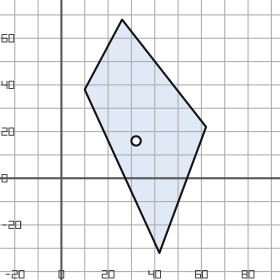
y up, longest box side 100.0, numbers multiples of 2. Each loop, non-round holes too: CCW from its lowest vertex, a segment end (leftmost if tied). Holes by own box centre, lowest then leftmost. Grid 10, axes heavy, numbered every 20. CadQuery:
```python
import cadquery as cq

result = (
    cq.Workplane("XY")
    .moveTo(42.0, -32.0)
    .lineTo(62.0, 22.0)
    .lineTo(26.0, 68.0)
    .lineTo(10.0, 38.0)
    .close()
    .moveTo(32.0, 16.0)
    .circle(2.0)
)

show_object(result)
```